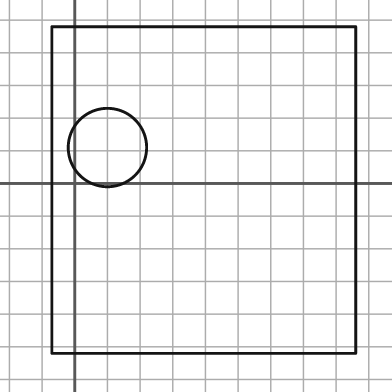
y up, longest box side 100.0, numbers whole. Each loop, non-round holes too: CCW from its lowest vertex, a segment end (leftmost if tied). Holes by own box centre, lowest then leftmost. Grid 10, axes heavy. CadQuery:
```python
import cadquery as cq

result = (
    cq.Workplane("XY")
    .moveTo(-7.0, -52.0)
    .lineTo(86.0, -52.0)
    .lineTo(86.0, 48.0)
    .lineTo(-7.0, 48.0)
    .close()
    .moveTo(10.0, 11.0)
    .circle(12.0)
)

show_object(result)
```